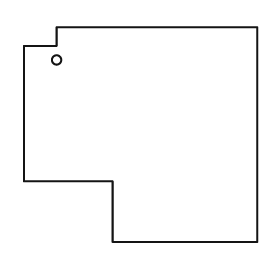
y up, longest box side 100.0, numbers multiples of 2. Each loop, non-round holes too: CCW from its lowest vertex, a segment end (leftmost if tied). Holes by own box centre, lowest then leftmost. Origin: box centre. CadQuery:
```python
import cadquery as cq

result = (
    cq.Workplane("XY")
    .moveTo(-12.0, -46.0)
    .lineTo(50.0, -46.0)
    .lineTo(50.0, 46.0)
    .lineTo(-36.0, 46.0)
    .lineTo(-36.0, 38.0)
    .lineTo(-50.0, 38.0)
    .lineTo(-50.0, -20.0)
    .lineTo(-12.0, -20.0)
    .close()
    .moveTo(-36.0, 32.0)
    .circle(2.0)
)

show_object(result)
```